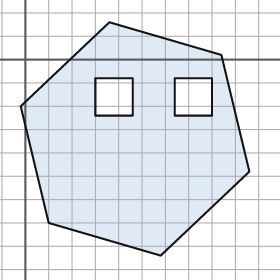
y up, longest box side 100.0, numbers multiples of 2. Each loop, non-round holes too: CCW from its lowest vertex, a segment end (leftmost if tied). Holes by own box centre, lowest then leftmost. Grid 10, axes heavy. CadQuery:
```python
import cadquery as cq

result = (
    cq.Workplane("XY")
    .moveTo(58.0, -84.0)
    .lineTo(96.0, -48.0)
    .lineTo(84.0, 2.0)
    .lineTo(36.0, 16.0)
    .lineTo(-2.0, -20.0)
    .lineTo(10.0, -70.0)
    .close()
    .moveTo(30.0, -24.0)
    .lineTo(46.0, -24.0)
    .lineTo(46.0, -8.0)
    .lineTo(30.0, -8.0)
    .close()
    .moveTo(64.0, -24.0)
    .lineTo(80.0, -24.0)
    .lineTo(80.0, -8.0)
    .lineTo(64.0, -8.0)
    .close()
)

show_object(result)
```